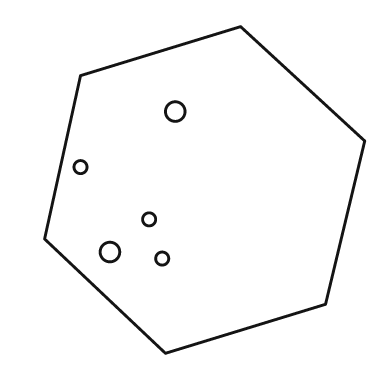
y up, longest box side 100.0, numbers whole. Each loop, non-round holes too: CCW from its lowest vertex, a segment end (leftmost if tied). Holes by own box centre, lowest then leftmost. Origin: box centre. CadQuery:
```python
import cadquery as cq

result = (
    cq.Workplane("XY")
    .moveTo(-12.0, -50.0)
    .lineTo(37.0, -35.0)
    .lineTo(49.0, 15.0)
    .lineTo(11.0, 50.0)
    .lineTo(-38.0, 35.0)
    .lineTo(-49.0, -15.0)
    .close()
    .moveTo(-13.0, -21.0)
    .circle(2.0)
    .moveTo(-29.0, -19.0)
    .circle(3.0)
    .moveTo(-17.0, -9.0)
    .circle(2.0)
    .moveTo(-38.0, 7.0)
    .circle(2.0)
    .moveTo(-9.0, 24.0)
    .circle(3.0)
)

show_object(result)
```